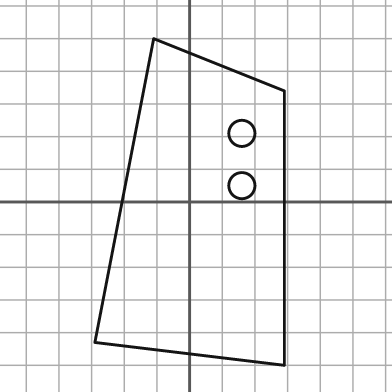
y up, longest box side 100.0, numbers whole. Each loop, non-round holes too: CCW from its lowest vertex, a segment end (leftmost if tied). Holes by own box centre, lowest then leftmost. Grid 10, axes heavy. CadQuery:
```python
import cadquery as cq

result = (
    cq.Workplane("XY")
    .moveTo(29.0, -50.0)
    .lineTo(29.0, 34.0)
    .lineTo(-11.0, 50.0)
    .lineTo(-29.0, -43.0)
    .close()
    .moveTo(16.0, 5.0)
    .circle(4.0)
    .moveTo(16.0, 21.0)
    .circle(4.0)
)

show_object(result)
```